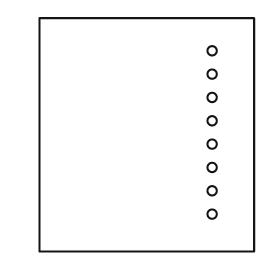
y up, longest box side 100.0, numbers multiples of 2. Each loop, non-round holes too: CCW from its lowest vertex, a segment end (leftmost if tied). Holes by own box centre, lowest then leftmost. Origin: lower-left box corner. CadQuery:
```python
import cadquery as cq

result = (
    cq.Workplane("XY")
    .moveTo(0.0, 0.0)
    .lineTo(92.0, 0.0)
    .lineTo(92.0, 100.0)
    .lineTo(0.0, 100.0)
    .close()
    .moveTo(74.0, 16.0)
    .circle(2.0)
    .moveTo(74.0, 26.0)
    .circle(2.0)
    .moveTo(74.0, 36.0)
    .circle(2.0)
    .moveTo(74.0, 46.0)
    .circle(2.0)
    .moveTo(74.0, 56.0)
    .circle(2.0)
    .moveTo(74.0, 66.0)
    .circle(2.0)
    .moveTo(74.0, 76.0)
    .circle(2.0)
    .moveTo(74.0, 86.0)
    .circle(2.0)
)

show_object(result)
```